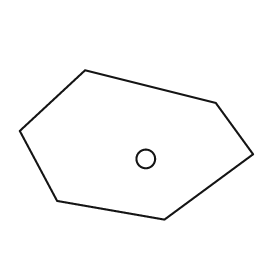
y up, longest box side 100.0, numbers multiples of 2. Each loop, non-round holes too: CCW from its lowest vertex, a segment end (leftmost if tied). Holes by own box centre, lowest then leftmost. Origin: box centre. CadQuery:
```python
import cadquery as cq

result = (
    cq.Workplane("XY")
    .moveTo(12.0, -32.0)
    .lineTo(50.0, -4.0)
    .lineTo(34.0, 18.0)
    .lineTo(-22.0, 32.0)
    .lineTo(-50.0, 6.0)
    .lineTo(-34.0, -24.0)
    .close()
    .moveTo(4.0, -6.0)
    .circle(4.0)
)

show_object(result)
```